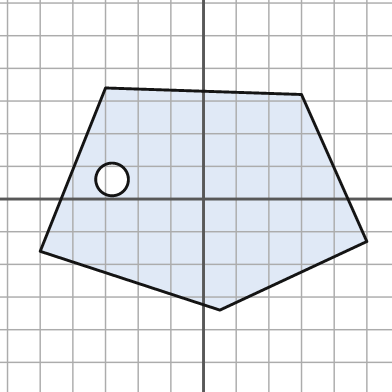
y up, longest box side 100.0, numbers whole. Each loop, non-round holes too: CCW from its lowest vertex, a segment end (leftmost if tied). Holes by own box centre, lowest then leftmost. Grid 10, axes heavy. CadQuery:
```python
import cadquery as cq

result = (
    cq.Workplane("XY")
    .moveTo(5.0, -34.0)
    .lineTo(50.0, -13.0)
    .lineTo(30.0, 32.0)
    .lineTo(-30.0, 34.0)
    .lineTo(-50.0, -16.0)
    .close()
    .moveTo(-28.0, 6.0)
    .circle(5.0)
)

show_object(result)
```